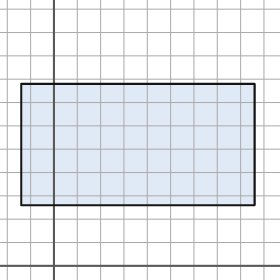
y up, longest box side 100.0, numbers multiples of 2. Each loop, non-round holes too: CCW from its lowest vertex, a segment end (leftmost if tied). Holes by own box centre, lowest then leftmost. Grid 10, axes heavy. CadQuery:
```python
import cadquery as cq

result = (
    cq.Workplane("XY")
    .moveTo(-14.0, 26.0)
    .lineTo(86.0, 26.0)
    .lineTo(86.0, 78.0)
    .lineTo(-14.0, 78.0)
    .close()
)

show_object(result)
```